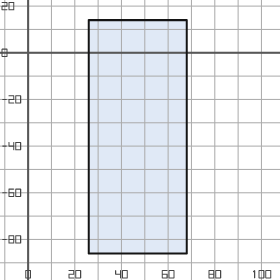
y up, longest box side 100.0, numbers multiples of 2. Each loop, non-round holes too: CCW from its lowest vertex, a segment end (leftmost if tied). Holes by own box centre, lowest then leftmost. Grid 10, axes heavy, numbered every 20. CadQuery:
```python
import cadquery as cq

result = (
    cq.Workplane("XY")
    .moveTo(26.0, -86.0)
    .lineTo(68.0, -86.0)
    .lineTo(68.0, 14.0)
    .lineTo(26.0, 14.0)
    .close()
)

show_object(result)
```